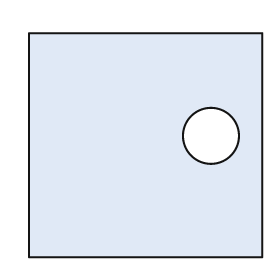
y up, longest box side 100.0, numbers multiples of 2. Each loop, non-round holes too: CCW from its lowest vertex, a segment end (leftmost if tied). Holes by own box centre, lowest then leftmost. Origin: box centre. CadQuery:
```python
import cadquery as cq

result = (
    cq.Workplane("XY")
    .moveTo(-50.0, -48.0)
    .lineTo(50.0, -48.0)
    .lineTo(50.0, 48.0)
    .lineTo(-50.0, 48.0)
    .close()
    .moveTo(28.0, 4.0)
    .circle(12.0)
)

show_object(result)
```